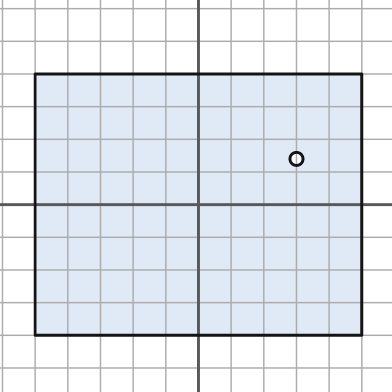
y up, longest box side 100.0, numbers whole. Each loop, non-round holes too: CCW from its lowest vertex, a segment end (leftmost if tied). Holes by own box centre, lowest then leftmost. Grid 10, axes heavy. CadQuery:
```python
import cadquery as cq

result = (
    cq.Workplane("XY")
    .moveTo(-50.0, -40.0)
    .lineTo(50.0, -40.0)
    .lineTo(50.0, 40.0)
    .lineTo(-50.0, 40.0)
    .close()
    .moveTo(30.0, 14.0)
    .circle(2.0)
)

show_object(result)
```